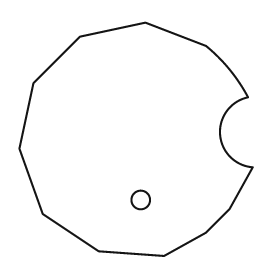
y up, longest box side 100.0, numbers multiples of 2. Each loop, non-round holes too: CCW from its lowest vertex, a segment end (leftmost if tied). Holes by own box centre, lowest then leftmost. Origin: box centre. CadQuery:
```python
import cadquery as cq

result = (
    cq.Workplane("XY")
    .moveTo(12.0, -50.0)
    .lineTo(30.0, -40.0)
    .lineTo(40.0, -30.0)
    .lineTo(50.0, -12.0)
    .threePointArc((36.0, 2.0), (48.0, 18.0))
    .threePointArc((40.0, 30.0), (30.0, 40.0))
    .lineTo(4.0, 50.0)
    .lineTo(-24.0, 44.0)
    .lineTo(-44.0, 24.0)
    .lineTo(-50.0, -4.0)
    .lineTo(-40.0, -32.0)
    .lineTo(-16.0, -48.0)
    .close()
    .moveTo(2.0, -26.0)
    .circle(4.0)
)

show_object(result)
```